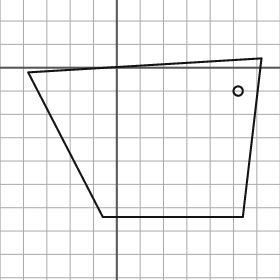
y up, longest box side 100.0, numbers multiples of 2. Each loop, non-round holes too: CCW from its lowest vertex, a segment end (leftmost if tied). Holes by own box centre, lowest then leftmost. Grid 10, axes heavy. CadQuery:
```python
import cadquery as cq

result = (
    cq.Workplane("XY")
    .moveTo(-6.0, -64.0)
    .lineTo(54.0, -64.0)
    .lineTo(62.0, 4.0)
    .lineTo(-38.0, -2.0)
    .close()
    .moveTo(52.0, -10.0)
    .circle(2.0)
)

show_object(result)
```